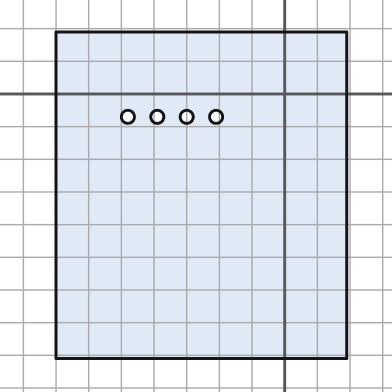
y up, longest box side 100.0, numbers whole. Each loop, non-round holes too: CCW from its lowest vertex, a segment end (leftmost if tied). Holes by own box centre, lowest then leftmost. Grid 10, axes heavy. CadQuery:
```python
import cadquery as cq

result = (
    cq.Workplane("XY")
    .moveTo(-70.0, -81.0)
    .lineTo(19.0, -81.0)
    .lineTo(19.0, 19.0)
    .lineTo(-70.0, 19.0)
    .close()
    .moveTo(-48.0, -7.0)
    .circle(2.0)
    .moveTo(-39.0, -7.0)
    .circle(2.0)
    .moveTo(-30.0, -7.0)
    .circle(2.0)
    .moveTo(-21.0, -7.0)
    .circle(2.0)
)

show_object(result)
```